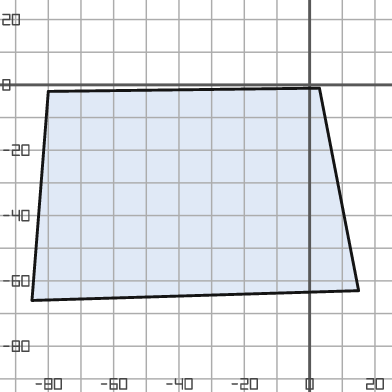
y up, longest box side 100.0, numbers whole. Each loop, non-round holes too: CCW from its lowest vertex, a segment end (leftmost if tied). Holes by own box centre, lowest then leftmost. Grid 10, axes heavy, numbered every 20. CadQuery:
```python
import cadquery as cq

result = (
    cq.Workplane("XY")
    .moveTo(-85.0, -66.0)
    .lineTo(15.0, -63.0)
    .lineTo(3.0, -1.0)
    .lineTo(-80.0, -2.0)
    .close()
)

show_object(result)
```